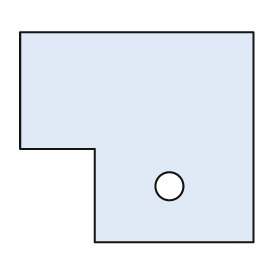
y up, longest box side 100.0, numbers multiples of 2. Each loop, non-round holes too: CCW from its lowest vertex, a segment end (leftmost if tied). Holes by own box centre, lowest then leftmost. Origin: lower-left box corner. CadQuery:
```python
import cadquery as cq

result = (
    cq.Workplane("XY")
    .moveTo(32.0, 0.0)
    .lineTo(100.0, 0.0)
    .lineTo(100.0, 90.0)
    .lineTo(0.0, 90.0)
    .lineTo(0.0, 40.0)
    .lineTo(32.0, 40.0)
    .close()
    .moveTo(64.0, 24.0)
    .circle(6.0)
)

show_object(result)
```